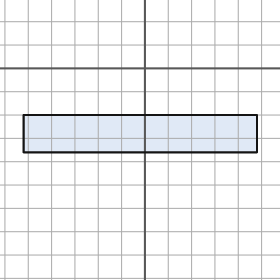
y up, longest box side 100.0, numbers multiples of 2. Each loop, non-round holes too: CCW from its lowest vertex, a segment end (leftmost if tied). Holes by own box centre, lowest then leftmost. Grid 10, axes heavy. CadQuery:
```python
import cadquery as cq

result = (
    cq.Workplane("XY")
    .moveTo(-52.0, -36.0)
    .lineTo(48.0, -36.0)
    .lineTo(48.0, -20.0)
    .lineTo(-52.0, -20.0)
    .close()
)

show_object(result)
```